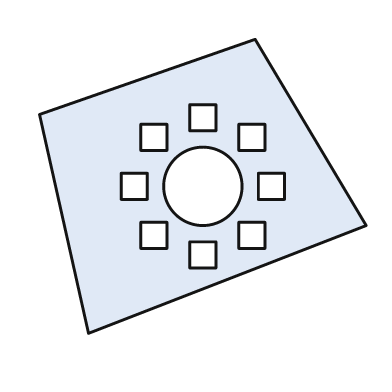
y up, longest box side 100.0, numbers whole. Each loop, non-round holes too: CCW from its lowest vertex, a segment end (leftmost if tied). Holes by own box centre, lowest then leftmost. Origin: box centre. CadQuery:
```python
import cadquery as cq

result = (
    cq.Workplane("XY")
    .moveTo(-35.0, -45.0)
    .lineTo(50.0, -12.0)
    .lineTo(16.0, 45.0)
    .lineTo(-50.0, 22.0)
    .close()
    .moveTo(-4.0, -25.0)
    .lineTo(4.0, -25.0)
    .lineTo(4.0, -17.0)
    .lineTo(-4.0, -17.0)
    .close()
    .moveTo(-19.0, -19.0)
    .lineTo(-11.0, -19.0)
    .lineTo(-11.0, -11.0)
    .lineTo(-19.0, -11.0)
    .close()
    .moveTo(11.0, -19.0)
    .lineTo(19.0, -19.0)
    .lineTo(19.0, -11.0)
    .lineTo(11.0, -11.0)
    .close()
    .moveTo(-25.0, -4.0)
    .lineTo(-17.0, -4.0)
    .lineTo(-17.0, 4.0)
    .lineTo(-25.0, 4.0)
    .close()
    .moveTo(0.0, 0.0)
    .circle(12.0)
    .moveTo(17.0, -4.0)
    .lineTo(25.0, -4.0)
    .lineTo(25.0, 4.0)
    .lineTo(17.0, 4.0)
    .close()
    .moveTo(-19.0, 11.0)
    .lineTo(-11.0, 11.0)
    .lineTo(-11.0, 19.0)
    .lineTo(-19.0, 19.0)
    .close()
    .moveTo(11.0, 11.0)
    .lineTo(19.0, 11.0)
    .lineTo(19.0, 19.0)
    .lineTo(11.0, 19.0)
    .close()
    .moveTo(-4.0, 17.0)
    .lineTo(4.0, 17.0)
    .lineTo(4.0, 25.0)
    .lineTo(-4.0, 25.0)
    .close()
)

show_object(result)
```